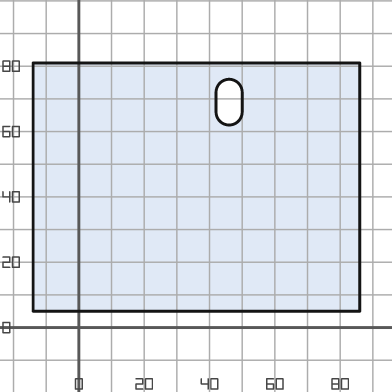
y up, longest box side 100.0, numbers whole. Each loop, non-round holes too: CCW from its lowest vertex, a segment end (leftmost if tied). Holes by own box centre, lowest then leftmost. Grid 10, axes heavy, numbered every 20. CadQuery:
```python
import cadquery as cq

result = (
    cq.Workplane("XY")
    .moveTo(-14.0, 5.0)
    .lineTo(86.0, 5.0)
    .lineTo(86.0, 81.0)
    .lineTo(-14.0, 81.0)
    .close()
    .moveTo(42.0, 66.0)
    .threePointArc((46.0, 62.0), (50.0, 66.0))
    .lineTo(50.0, 72.0)
    .threePointArc((46.0, 76.0), (42.0, 72.0))
    .close()
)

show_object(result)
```